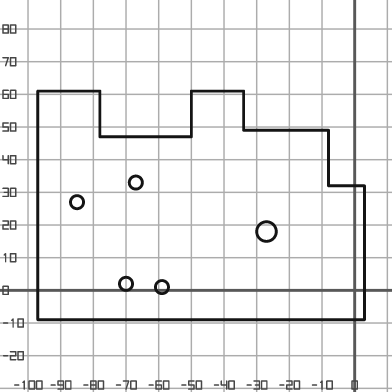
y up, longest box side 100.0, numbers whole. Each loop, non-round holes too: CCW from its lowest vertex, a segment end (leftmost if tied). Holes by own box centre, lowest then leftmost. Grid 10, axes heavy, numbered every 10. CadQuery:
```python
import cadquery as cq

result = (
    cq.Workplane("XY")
    .moveTo(-97.0, -9.0)
    .lineTo(3.0, -9.0)
    .lineTo(3.0, 32.0)
    .lineTo(-8.0, 32.0)
    .lineTo(-8.0, 49.0)
    .lineTo(-34.0, 49.0)
    .lineTo(-34.0, 61.0)
    .lineTo(-50.0, 61.0)
    .lineTo(-50.0, 47.0)
    .lineTo(-78.0, 47.0)
    .lineTo(-78.0, 61.0)
    .lineTo(-97.0, 61.0)
    .close()
    .moveTo(-59.0, 1.0)
    .circle(2.0)
    .moveTo(-70.0, 2.0)
    .circle(2.0)
    .moveTo(-27.0, 18.0)
    .circle(3.0)
    .moveTo(-85.0, 27.0)
    .circle(2.0)
    .moveTo(-67.0, 33.0)
    .circle(2.0)
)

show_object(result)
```